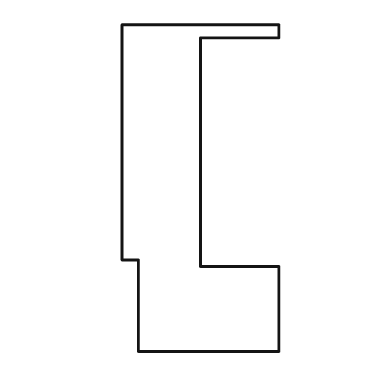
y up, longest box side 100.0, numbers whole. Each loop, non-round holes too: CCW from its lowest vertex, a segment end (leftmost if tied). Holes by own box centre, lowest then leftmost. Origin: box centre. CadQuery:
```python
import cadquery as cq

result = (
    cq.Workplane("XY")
    .moveTo(-19.0, -50.0)
    .lineTo(24.0, -50.0)
    .lineTo(24.0, -24.0)
    .lineTo(0.0, -24.0)
    .lineTo(0.0, 46.0)
    .lineTo(24.0, 46.0)
    .lineTo(24.0, 50.0)
    .lineTo(-24.0, 50.0)
    .lineTo(-24.0, -22.0)
    .lineTo(-19.0, -22.0)
    .close()
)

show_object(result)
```